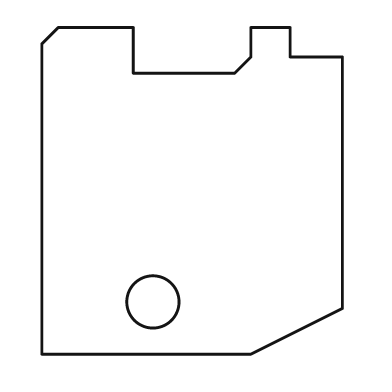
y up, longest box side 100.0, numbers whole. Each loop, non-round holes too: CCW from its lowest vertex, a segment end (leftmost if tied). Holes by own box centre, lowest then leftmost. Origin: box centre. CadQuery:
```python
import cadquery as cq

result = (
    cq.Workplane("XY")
    .moveTo(-46.0, -50.0)
    .lineTo(18.0, -50.0)
    .lineTo(46.0, -36.0)
    .lineTo(46.0, 41.0)
    .lineTo(30.0, 41.0)
    .lineTo(30.0, 50.0)
    .lineTo(18.0, 50.0)
    .lineTo(18.0, 41.0)
    .lineTo(13.0, 36.0)
    .lineTo(-18.0, 36.0)
    .lineTo(-18.0, 50.0)
    .lineTo(-41.0, 50.0)
    .lineTo(-46.0, 45.0)
    .close()
    .moveTo(-12.0, -34.0)
    .circle(8.0)
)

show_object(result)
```